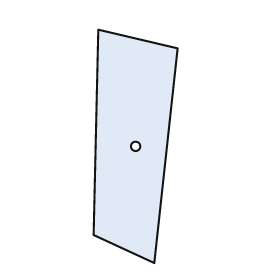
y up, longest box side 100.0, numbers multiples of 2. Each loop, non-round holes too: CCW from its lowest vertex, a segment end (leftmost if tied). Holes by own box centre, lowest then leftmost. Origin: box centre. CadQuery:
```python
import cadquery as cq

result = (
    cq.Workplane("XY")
    .moveTo(8.0, -50.0)
    .lineTo(18.0, 42.0)
    .lineTo(-16.0, 50.0)
    .lineTo(-18.0, -38.0)
    .close()
    .moveTo(0.0, 0.0)
    .circle(2.0)
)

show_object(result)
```